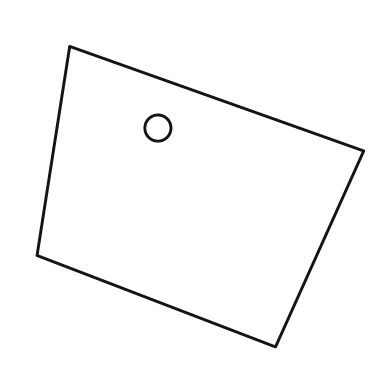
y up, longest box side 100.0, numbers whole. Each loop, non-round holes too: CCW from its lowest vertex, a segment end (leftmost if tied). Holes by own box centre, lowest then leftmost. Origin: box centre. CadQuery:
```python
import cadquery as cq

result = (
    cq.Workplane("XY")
    .moveTo(23.0, -46.0)
    .lineTo(50.0, 14.0)
    .lineTo(-40.0, 46.0)
    .lineTo(-50.0, -18.0)
    .close()
    .moveTo(-13.0, 21.0)
    .circle(4.0)
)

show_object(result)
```